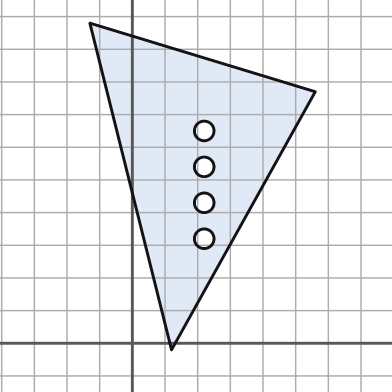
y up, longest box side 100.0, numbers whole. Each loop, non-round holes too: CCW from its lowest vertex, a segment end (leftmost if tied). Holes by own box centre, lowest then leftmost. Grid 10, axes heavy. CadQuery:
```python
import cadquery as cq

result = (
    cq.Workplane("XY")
    .moveTo(12.0, -2.0)
    .lineTo(56.0, 77.0)
    .lineTo(-13.0, 98.0)
    .close()
    .moveTo(22.0, 32.0)
    .circle(3.0)
    .moveTo(22.0, 43.0)
    .circle(3.0)
    .moveTo(22.0, 54.0)
    .circle(3.0)
    .moveTo(22.0, 65.0)
    .circle(3.0)
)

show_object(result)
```